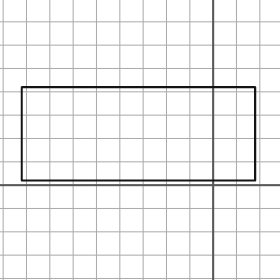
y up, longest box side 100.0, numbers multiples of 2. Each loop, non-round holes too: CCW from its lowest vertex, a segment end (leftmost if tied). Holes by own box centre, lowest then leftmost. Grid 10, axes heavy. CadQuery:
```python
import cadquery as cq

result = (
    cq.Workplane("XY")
    .moveTo(-82.0, 2.0)
    .lineTo(18.0, 2.0)
    .lineTo(18.0, 42.0)
    .lineTo(-82.0, 42.0)
    .close()
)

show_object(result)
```